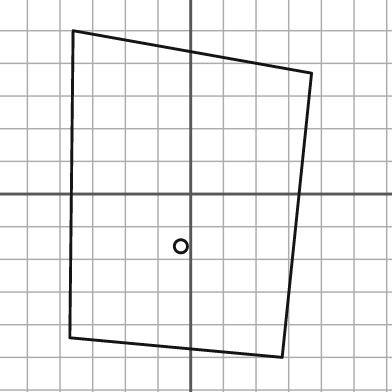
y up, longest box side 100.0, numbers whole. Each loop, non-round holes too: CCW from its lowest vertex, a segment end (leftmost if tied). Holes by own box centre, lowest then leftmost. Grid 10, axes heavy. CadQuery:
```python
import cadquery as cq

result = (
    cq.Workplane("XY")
    .moveTo(28.0, -50.0)
    .lineTo(37.0, 37.0)
    .lineTo(-36.0, 50.0)
    .lineTo(-37.0, -44.0)
    .close()
    .moveTo(-3.0, -16.0)
    .circle(2.0)
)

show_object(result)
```